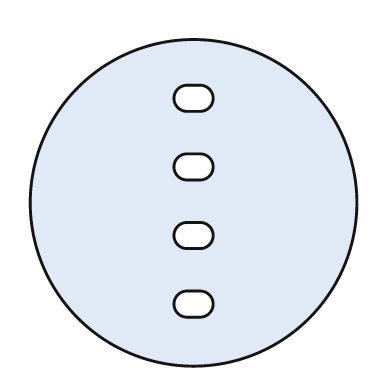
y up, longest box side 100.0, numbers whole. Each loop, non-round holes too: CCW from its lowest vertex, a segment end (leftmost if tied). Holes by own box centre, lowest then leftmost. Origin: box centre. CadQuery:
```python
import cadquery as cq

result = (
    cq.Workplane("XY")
    .moveTo(0.0, 0.0)
    .circle(50.0)
    .moveTo(-2.0, -35.0)
    .lineTo(2.0, -35.0)
    .threePointArc((6.0, -31.0), (2.0, -27.0))
    .lineTo(-2.0, -27.0)
    .threePointArc((-6.0, -31.0), (-2.0, -35.0))
    .close()
    .moveTo(-2.0, -14.0)
    .lineTo(2.0, -14.0)
    .threePointArc((6.0, -10.0), (2.0, -6.0))
    .lineTo(-2.0, -6.0)
    .threePointArc((-6.0, -10.0), (-2.0, -14.0))
    .close()
    .moveTo(-2.0, 7.0)
    .lineTo(2.0, 7.0)
    .threePointArc((6.0, 11.0), (2.0, 15.0))
    .lineTo(-2.0, 15.0)
    .threePointArc((-6.0, 11.0), (-2.0, 7.0))
    .close()
    .moveTo(-2.0, 28.0)
    .lineTo(2.0, 28.0)
    .threePointArc((6.0, 32.0), (2.0, 36.0))
    .lineTo(-2.0, 36.0)
    .threePointArc((-6.0, 32.0), (-2.0, 28.0))
    .close()
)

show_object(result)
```